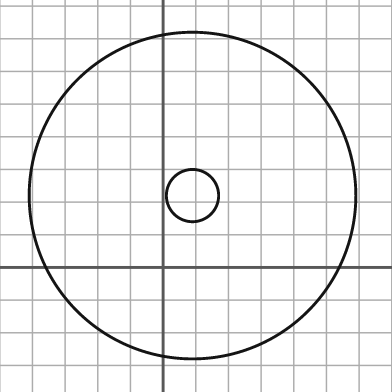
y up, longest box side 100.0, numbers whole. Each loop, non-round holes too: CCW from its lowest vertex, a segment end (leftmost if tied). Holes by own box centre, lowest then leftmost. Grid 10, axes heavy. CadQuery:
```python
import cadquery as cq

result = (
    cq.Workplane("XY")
    .moveTo(9.0, 22.0)
    .circle(50.0)
    .moveTo(9.0, 22.0)
    .circle(8.0)
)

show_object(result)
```